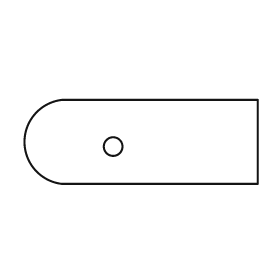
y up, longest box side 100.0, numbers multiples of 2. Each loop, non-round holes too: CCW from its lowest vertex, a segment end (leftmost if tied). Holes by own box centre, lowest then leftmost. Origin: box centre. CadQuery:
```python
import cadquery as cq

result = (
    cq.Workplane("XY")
    .moveTo(-34.0, -18.0)
    .lineTo(50.0, -18.0)
    .lineTo(50.0, 18.0)
    .lineTo(-34.0, 18.0)
    .threePointArc((-50.0, 0.0), (-34.0, -18.0))
    .close()
    .moveTo(-12.0, -2.0)
    .circle(4.0)
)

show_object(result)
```